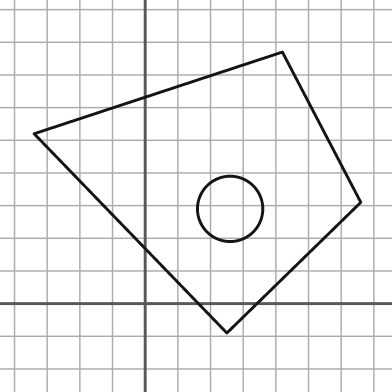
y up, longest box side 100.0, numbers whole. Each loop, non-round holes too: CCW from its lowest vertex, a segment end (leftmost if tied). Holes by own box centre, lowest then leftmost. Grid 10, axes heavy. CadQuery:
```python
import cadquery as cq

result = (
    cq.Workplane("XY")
    .moveTo(25.0, -9.0)
    .lineTo(66.0, 31.0)
    .lineTo(42.0, 77.0)
    .lineTo(-34.0, 52.0)
    .close()
    .moveTo(26.0, 29.0)
    .circle(10.0)
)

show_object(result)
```